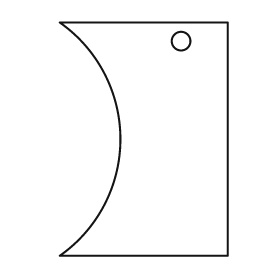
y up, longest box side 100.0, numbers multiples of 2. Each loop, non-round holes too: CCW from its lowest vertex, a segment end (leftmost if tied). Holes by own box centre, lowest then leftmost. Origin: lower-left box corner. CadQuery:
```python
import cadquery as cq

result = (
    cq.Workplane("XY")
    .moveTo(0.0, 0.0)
    .lineTo(72.0, 0.0)
    .lineTo(72.0, 100.0)
    .lineTo(0.0, 100.0)
    .threePointArc((26.0, 50.0), (0.0, 0.0))
    .close()
    .moveTo(52.0, 92.0)
    .circle(4.0)
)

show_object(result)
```